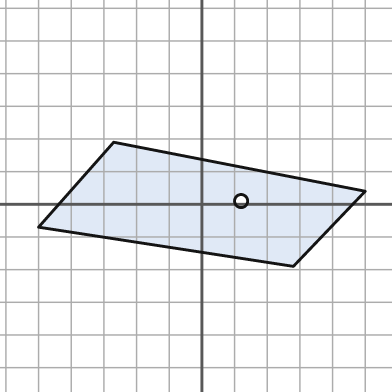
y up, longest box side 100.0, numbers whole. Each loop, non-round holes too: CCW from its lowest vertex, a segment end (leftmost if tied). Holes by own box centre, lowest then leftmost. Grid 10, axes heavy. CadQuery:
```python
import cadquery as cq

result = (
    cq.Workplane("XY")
    .moveTo(28.0, -19.0)
    .lineTo(50.0, 4.0)
    .lineTo(-27.0, 19.0)
    .lineTo(-50.0, -7.0)
    .close()
    .moveTo(12.0, 1.0)
    .circle(2.0)
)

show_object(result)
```